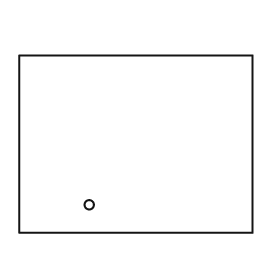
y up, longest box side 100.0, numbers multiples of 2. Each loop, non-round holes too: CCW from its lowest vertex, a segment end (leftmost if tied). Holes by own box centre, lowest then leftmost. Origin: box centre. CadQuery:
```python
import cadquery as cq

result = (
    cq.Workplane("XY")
    .moveTo(-50.0, -38.0)
    .lineTo(50.0, -38.0)
    .lineTo(50.0, 38.0)
    .lineTo(-50.0, 38.0)
    .close()
    .moveTo(-20.0, -26.0)
    .circle(2.0)
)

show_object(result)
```